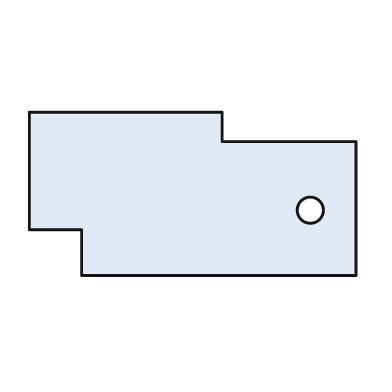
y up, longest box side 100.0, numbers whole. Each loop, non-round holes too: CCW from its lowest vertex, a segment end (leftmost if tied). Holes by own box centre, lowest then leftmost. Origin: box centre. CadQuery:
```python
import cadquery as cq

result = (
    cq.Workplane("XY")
    .moveTo(-34.0, -25.0)
    .lineTo(50.0, -25.0)
    .lineTo(50.0, 16.0)
    .lineTo(9.0, 16.0)
    .lineTo(9.0, 25.0)
    .lineTo(-50.0, 25.0)
    .lineTo(-50.0, -11.0)
    .lineTo(-34.0, -11.0)
    .close()
    .moveTo(36.0, -5.0)
    .circle(4.0)
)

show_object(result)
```